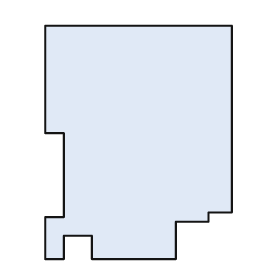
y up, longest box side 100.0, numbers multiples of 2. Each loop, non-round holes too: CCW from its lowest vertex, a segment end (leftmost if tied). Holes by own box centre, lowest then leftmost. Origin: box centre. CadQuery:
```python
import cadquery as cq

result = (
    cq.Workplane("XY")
    .moveTo(-40.0, -50.0)
    .lineTo(-32.0, -50.0)
    .lineTo(-32.0, -40.0)
    .lineTo(-20.0, -40.0)
    .lineTo(-20.0, -50.0)
    .lineTo(16.0, -50.0)
    .lineTo(16.0, -34.0)
    .lineTo(30.0, -34.0)
    .lineTo(30.0, -30.0)
    .lineTo(40.0, -30.0)
    .lineTo(40.0, 50.0)
    .lineTo(-40.0, 50.0)
    .lineTo(-40.0, 4.0)
    .lineTo(-32.0, 4.0)
    .lineTo(-32.0, -32.0)
    .lineTo(-40.0, -32.0)
    .close()
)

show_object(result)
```